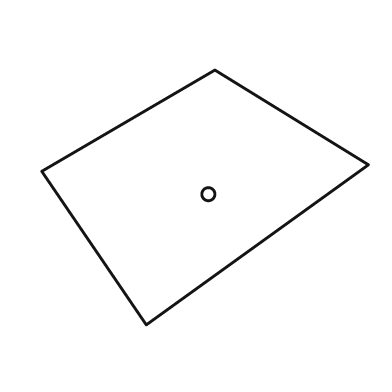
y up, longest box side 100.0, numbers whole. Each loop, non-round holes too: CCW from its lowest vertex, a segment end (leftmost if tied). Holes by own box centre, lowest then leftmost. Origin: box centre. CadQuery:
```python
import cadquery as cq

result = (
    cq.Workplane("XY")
    .moveTo(-18.0, -39.0)
    .lineTo(50.0, 10.0)
    .lineTo(3.0, 39.0)
    .lineTo(-50.0, 8.0)
    .close()
    .moveTo(1.0, 1.0)
    .circle(2.0)
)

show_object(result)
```